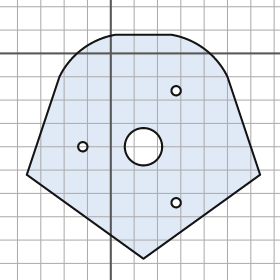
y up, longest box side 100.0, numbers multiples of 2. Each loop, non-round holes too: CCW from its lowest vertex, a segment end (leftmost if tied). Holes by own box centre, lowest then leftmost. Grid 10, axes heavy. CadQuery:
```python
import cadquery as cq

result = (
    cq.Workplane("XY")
    .moveTo(14.0, -88.0)
    .lineTo(64.0, -52.0)
    .lineTo(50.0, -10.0)
    .threePointArc((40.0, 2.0), (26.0, 8.0))
    .lineTo(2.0, 8.0)
    .threePointArc((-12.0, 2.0), (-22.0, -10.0))
    .lineTo(-36.0, -52.0)
    .close()
    .moveTo(28.0, -64.0)
    .circle(2.0)
    .moveTo(-12.0, -40.0)
    .circle(2.0)
    .moveTo(14.0, -40.0)
    .circle(8.0)
    .moveTo(28.0, -16.0)
    .circle(2.0)
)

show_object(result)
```